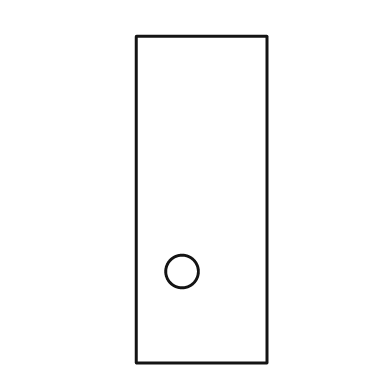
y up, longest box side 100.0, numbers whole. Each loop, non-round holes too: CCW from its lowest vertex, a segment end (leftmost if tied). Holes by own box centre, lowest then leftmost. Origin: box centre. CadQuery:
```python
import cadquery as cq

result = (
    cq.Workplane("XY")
    .moveTo(-20.0, -50.0)
    .lineTo(20.0, -50.0)
    .lineTo(20.0, 50.0)
    .lineTo(-20.0, 50.0)
    .close()
    .moveTo(-6.0, -22.0)
    .circle(5.0)
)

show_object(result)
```